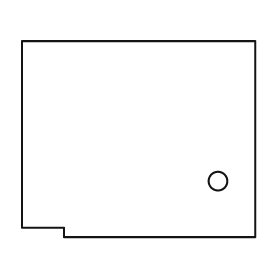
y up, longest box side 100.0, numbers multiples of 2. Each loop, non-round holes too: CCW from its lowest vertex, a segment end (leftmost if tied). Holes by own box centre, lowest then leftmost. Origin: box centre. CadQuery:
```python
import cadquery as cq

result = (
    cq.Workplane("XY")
    .moveTo(-32.0, -42.0)
    .lineTo(50.0, -42.0)
    .lineTo(50.0, 42.0)
    .lineTo(-50.0, 42.0)
    .lineTo(-50.0, -38.0)
    .lineTo(-32.0, -38.0)
    .close()
    .moveTo(34.0, -18.0)
    .circle(4.0)
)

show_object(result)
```